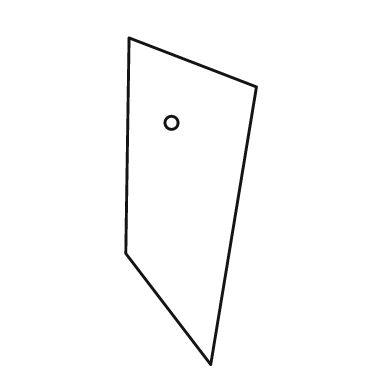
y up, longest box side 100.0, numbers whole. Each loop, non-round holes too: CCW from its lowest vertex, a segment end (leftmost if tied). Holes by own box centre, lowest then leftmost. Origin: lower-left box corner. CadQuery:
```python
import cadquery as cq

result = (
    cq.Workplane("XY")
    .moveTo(26.0, 0.0)
    .lineTo(40.0, 85.0)
    .lineTo(1.0, 100.0)
    .lineTo(0.0, 34.0)
    .close()
    .moveTo(14.0, 74.0)
    .circle(2.0)
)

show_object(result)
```